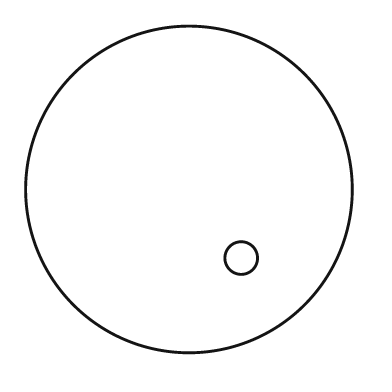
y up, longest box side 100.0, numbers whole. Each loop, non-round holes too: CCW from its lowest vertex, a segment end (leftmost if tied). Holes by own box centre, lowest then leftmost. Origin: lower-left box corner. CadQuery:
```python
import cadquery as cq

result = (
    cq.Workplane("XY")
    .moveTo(50.0, 50.0)
    .circle(50.0)
    .moveTo(66.0, 29.0)
    .circle(5.0)
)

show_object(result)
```